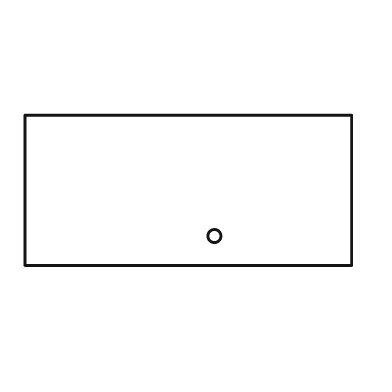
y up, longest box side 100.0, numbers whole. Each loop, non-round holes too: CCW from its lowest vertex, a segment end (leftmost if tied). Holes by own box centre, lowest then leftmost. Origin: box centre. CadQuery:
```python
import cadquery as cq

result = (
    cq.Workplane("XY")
    .moveTo(-50.0, -23.0)
    .lineTo(50.0, -23.0)
    .lineTo(50.0, 23.0)
    .lineTo(-50.0, 23.0)
    .close()
    .moveTo(8.0, -14.0)
    .circle(2.0)
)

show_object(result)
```